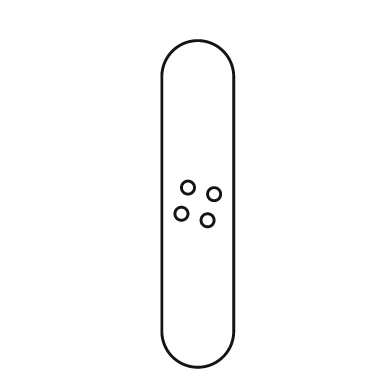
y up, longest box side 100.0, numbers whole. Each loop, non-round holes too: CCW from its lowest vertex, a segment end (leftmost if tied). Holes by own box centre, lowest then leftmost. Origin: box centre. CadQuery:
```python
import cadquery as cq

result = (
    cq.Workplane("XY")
    .moveTo(-11.0, -39.0)
    .threePointArc((0.0, -50.0), (11.0, -39.0))
    .lineTo(11.0, 39.0)
    .threePointArc((0.0, 50.0), (-11.0, 39.0))
    .close()
    .moveTo(3.0, -5.0)
    .circle(2.0)
    .moveTo(-5.0, -3.0)
    .circle(2.0)
    .moveTo(5.0, 3.0)
    .circle(2.0)
    .moveTo(-3.0, 5.0)
    .circle(2.0)
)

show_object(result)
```